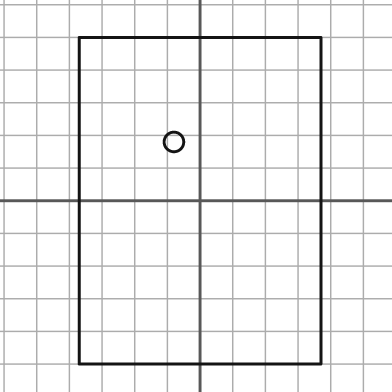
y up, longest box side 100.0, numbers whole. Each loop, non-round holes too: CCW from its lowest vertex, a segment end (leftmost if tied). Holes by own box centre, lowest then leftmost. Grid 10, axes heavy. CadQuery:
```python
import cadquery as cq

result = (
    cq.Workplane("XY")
    .moveTo(-37.0, -50.0)
    .lineTo(37.0, -50.0)
    .lineTo(37.0, 50.0)
    .lineTo(-37.0, 50.0)
    .close()
    .moveTo(-8.0, 18.0)
    .circle(3.0)
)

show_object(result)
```